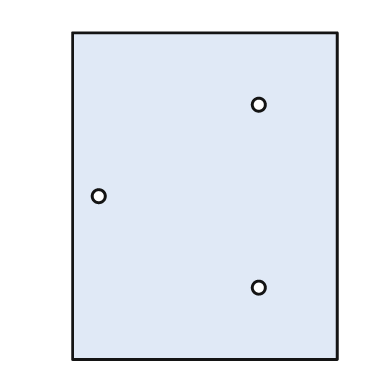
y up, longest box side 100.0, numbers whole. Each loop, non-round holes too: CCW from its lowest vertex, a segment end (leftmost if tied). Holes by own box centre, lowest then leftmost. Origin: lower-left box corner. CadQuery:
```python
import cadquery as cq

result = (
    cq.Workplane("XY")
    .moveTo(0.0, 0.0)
    .lineTo(81.0, 0.0)
    .lineTo(81.0, 100.0)
    .lineTo(0.0, 100.0)
    .close()
    .moveTo(57.0, 22.0)
    .circle(2.0)
    .moveTo(8.0, 50.0)
    .circle(2.0)
    .moveTo(57.0, 78.0)
    .circle(2.0)
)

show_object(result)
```